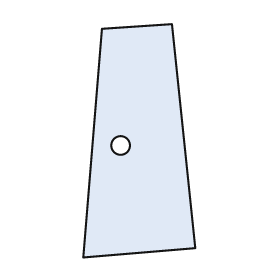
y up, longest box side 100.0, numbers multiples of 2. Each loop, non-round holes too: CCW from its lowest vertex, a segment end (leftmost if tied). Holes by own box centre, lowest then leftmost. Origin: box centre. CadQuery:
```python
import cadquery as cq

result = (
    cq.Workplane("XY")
    .moveTo(-24.0, -50.0)
    .lineTo(24.0, -46.0)
    .lineTo(14.0, 50.0)
    .lineTo(-16.0, 48.0)
    .close()
    .moveTo(-8.0, -2.0)
    .circle(4.0)
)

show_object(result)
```